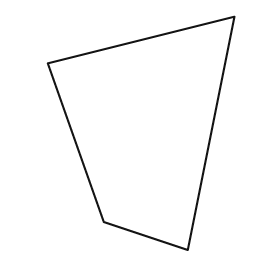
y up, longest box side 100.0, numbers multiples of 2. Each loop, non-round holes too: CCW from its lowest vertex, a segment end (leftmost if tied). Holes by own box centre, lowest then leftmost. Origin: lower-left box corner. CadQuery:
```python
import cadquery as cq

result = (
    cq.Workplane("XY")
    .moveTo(60.0, 0.0)
    .lineTo(80.0, 100.0)
    .lineTo(0.0, 80.0)
    .lineTo(24.0, 12.0)
    .close()
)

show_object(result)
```